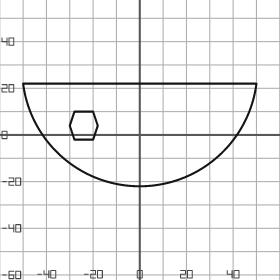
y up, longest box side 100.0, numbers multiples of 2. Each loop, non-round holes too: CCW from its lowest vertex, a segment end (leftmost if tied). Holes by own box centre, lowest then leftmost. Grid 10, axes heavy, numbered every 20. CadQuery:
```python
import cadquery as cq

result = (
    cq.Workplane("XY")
    .moveTo(-50.0, 22.0)
    .threePointArc((0.0, -22.0), (50.0, 22.0))
    .close()
    .moveTo(-28.0, -2.0)
    .lineTo(-20.0, -2.0)
    .lineTo(-18.0, 4.0)
    .lineTo(-20.0, 10.0)
    .lineTo(-28.0, 10.0)
    .lineTo(-30.0, 4.0)
    .close()
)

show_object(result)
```